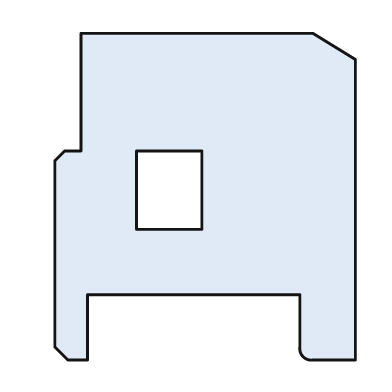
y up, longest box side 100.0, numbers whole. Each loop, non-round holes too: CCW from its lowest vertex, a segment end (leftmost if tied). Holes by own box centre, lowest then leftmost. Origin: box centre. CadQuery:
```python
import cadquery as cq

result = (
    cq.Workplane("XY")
    .moveTo(-42.0, -50.0)
    .lineTo(-36.0, -50.0)
    .lineTo(-36.0, -30.0)
    .lineTo(29.0, -30.0)
    .lineTo(29.0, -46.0)
    .threePointArc((30.0, -49.0), (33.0, -50.0))
    .lineTo(46.0, -50.0)
    .lineTo(46.0, 42.0)
    .lineTo(33.0, 50.0)
    .lineTo(-38.0, 50.0)
    .lineTo(-38.0, 14.0)
    .lineTo(-43.0, 14.0)
    .lineTo(-46.0, 11.0)
    .lineTo(-46.0, -46.0)
    .close()
    .moveTo(-21.0, -10.0)
    .lineTo(-1.0, -10.0)
    .lineTo(-1.0, 14.0)
    .lineTo(-21.0, 14.0)
    .close()
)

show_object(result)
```